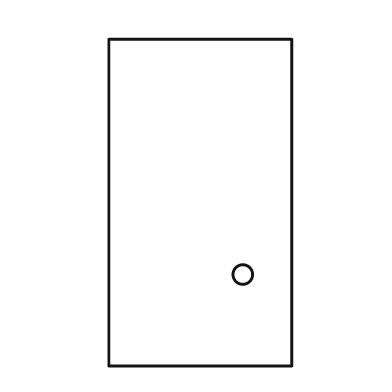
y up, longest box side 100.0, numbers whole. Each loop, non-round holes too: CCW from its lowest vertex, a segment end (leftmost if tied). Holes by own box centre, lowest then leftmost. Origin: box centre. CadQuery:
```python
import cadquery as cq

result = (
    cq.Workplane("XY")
    .moveTo(-28.0, -50.0)
    .lineTo(28.0, -50.0)
    .lineTo(28.0, 50.0)
    .lineTo(-28.0, 50.0)
    .close()
    .moveTo(13.0, -22.0)
    .circle(3.0)
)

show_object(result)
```